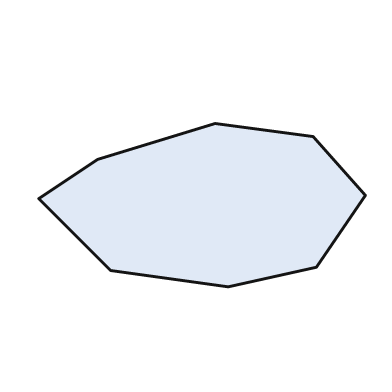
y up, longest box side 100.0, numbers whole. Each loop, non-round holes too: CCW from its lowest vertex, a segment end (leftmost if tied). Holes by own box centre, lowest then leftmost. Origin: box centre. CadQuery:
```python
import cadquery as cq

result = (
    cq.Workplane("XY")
    .moveTo(8.0, -25.0)
    .lineTo(35.0, -19.0)
    .lineTo(50.0, 3.0)
    .lineTo(34.0, 21.0)
    .lineTo(4.0, 25.0)
    .lineTo(-32.0, 14.0)
    .lineTo(-50.0, 2.0)
    .lineTo(-28.0, -20.0)
    .close()
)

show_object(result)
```